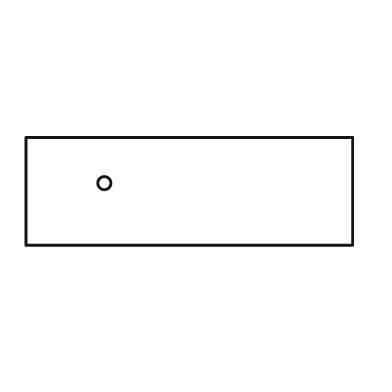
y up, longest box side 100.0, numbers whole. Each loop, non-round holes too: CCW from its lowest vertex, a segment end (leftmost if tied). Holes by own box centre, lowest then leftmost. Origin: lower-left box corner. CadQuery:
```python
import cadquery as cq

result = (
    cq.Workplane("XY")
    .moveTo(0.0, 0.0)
    .lineTo(100.0, 0.0)
    .lineTo(100.0, 33.0)
    .lineTo(0.0, 33.0)
    .close()
    .moveTo(24.0, 19.0)
    .circle(2.0)
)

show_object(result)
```